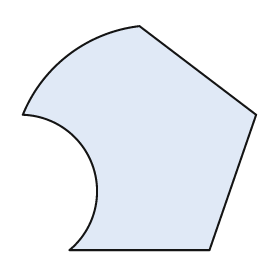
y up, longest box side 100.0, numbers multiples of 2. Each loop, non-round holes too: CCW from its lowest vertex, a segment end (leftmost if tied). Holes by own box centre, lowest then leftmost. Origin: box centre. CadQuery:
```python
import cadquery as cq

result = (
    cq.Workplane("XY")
    .moveTo(-30.0, -48.0)
    .lineTo(30.0, -48.0)
    .lineTo(50.0, 10.0)
    .lineTo(0.0, 48.0)
    .threePointArc((-30.0, 36.0), (-50.0, 10.0))
    .threePointArc((-20.0, -12.0), (-30.0, -48.0))
    .close()
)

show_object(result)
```